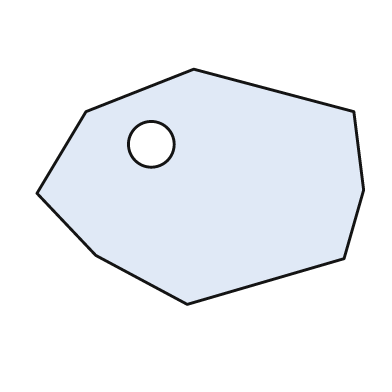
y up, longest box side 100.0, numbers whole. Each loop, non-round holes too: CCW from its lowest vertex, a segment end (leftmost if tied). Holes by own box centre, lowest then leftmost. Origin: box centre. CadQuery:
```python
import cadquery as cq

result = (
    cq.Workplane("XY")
    .moveTo(-4.0, -36.0)
    .lineTo(44.0, -22.0)
    .lineTo(50.0, -1.0)
    .lineTo(47.0, 23.0)
    .lineTo(-2.0, 36.0)
    .lineTo(-35.0, 23.0)
    .lineTo(-50.0, -2.0)
    .lineTo(-32.0, -21.0)
    .close()
    .moveTo(-15.0, 13.0)
    .circle(7.0)
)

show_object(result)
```